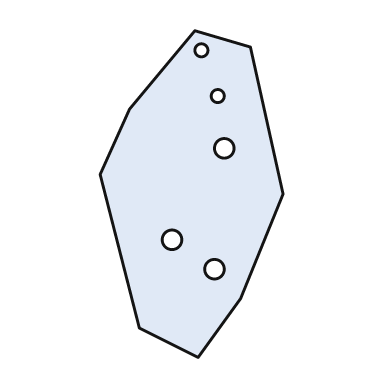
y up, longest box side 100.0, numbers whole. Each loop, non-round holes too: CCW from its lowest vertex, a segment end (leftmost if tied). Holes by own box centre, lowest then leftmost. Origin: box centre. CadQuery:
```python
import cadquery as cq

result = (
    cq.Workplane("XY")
    .moveTo(2.0, -50.0)
    .lineTo(15.0, -32.0)
    .lineTo(28.0, 0.0)
    .lineTo(18.0, 45.0)
    .lineTo(1.0, 50.0)
    .lineTo(-19.0, 26.0)
    .lineTo(-28.0, 6.0)
    .lineTo(-16.0, -41.0)
    .close()
    .moveTo(7.0, -23.0)
    .circle(3.0)
    .moveTo(-6.0, -14.0)
    .circle(3.0)
    .moveTo(10.0, 14.0)
    .circle(3.0)
    .moveTo(8.0, 30.0)
    .circle(2.0)
    .moveTo(3.0, 44.0)
    .circle(2.0)
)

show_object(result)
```